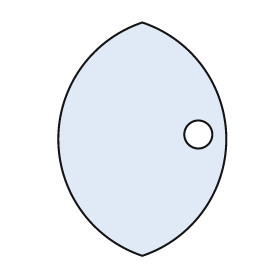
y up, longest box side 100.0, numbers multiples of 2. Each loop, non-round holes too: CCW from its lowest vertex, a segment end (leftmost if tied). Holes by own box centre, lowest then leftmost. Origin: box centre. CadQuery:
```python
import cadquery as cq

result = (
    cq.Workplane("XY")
    .moveTo(0.0, -50.0)
    .threePointArc((36.0, 0.0), (0.0, 50.0))
    .threePointArc((-36.0, 0.0), (0.0, -50.0))
    .close()
    .moveTo(24.0, 2.0)
    .circle(6.0)
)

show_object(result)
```